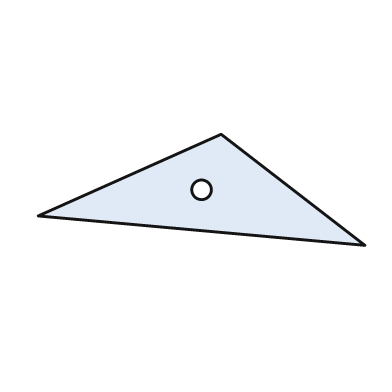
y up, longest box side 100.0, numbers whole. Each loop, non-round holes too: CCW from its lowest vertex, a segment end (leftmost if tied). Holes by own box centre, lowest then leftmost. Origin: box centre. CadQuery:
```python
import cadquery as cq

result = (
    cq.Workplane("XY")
    .moveTo(50.0, -17.0)
    .lineTo(6.0, 17.0)
    .lineTo(-50.0, -8.0)
    .close()
    .moveTo(0.0, 0.0)
    .circle(3.0)
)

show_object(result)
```